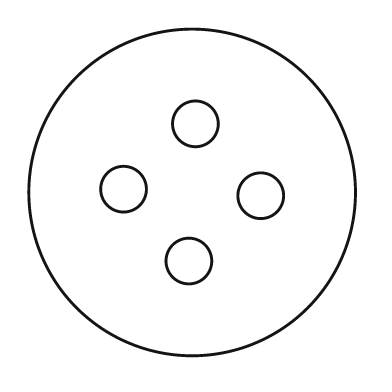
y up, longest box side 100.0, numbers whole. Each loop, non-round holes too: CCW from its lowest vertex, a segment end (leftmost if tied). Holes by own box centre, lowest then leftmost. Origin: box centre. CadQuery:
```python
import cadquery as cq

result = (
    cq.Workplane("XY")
    .moveTo(0.0, 0.0)
    .circle(50.0)
    .moveTo(-1.0, -21.0)
    .circle(7.0)
    .moveTo(21.0, -1.0)
    .circle(7.0)
    .moveTo(-21.0, 1.0)
    .circle(7.0)
    .moveTo(1.0, 21.0)
    .circle(7.0)
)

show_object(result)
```